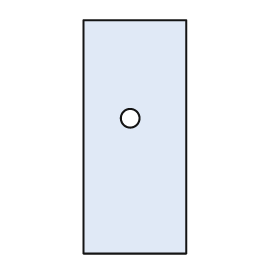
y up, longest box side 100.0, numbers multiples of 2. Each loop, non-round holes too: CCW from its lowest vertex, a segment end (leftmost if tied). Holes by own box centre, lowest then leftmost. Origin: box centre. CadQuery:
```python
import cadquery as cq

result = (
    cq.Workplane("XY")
    .moveTo(-22.0, -50.0)
    .lineTo(22.0, -50.0)
    .lineTo(22.0, 50.0)
    .lineTo(-22.0, 50.0)
    .close()
    .moveTo(-2.0, 8.0)
    .circle(4.0)
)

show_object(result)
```